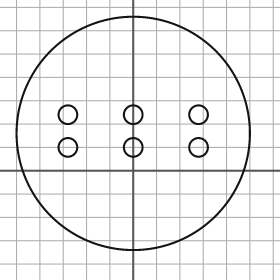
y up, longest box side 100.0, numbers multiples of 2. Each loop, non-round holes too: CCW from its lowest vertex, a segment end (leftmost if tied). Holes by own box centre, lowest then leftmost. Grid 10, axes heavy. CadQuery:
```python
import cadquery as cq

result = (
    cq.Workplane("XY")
    .moveTo(0.0, 16.0)
    .circle(50.0)
    .moveTo(-28.0, 10.0)
    .circle(4.0)
    .moveTo(0.0, 10.0)
    .circle(4.0)
    .moveTo(28.0, 10.0)
    .circle(4.0)
    .moveTo(-28.0, 24.0)
    .circle(4.0)
    .moveTo(0.0, 24.0)
    .circle(4.0)
    .moveTo(28.0, 24.0)
    .circle(4.0)
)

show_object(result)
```